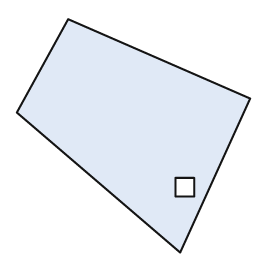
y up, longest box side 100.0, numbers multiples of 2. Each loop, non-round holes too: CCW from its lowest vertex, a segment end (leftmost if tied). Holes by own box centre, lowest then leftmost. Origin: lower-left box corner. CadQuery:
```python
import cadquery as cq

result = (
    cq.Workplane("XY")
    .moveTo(70.0, 0.0)
    .lineTo(100.0, 66.0)
    .lineTo(22.0, 100.0)
    .lineTo(0.0, 60.0)
    .close()
    .moveTo(68.0, 24.0)
    .lineTo(76.0, 24.0)
    .lineTo(76.0, 32.0)
    .lineTo(68.0, 32.0)
    .close()
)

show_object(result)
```